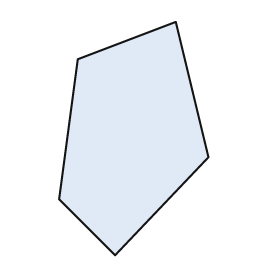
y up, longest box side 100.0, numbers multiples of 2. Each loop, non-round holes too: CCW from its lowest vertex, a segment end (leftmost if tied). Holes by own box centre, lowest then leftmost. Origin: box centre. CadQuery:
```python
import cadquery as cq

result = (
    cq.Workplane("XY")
    .moveTo(-8.0, -50.0)
    .lineTo(32.0, -8.0)
    .lineTo(18.0, 50.0)
    .lineTo(-24.0, 34.0)
    .lineTo(-32.0, -26.0)
    .close()
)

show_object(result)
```